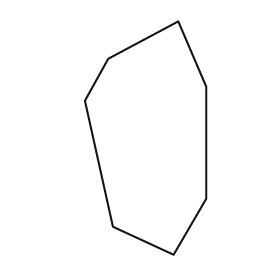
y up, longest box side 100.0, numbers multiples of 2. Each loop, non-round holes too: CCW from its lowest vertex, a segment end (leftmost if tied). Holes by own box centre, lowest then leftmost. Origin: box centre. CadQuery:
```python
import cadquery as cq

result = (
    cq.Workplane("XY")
    .moveTo(12.0, -50.0)
    .lineTo(26.0, -26.0)
    .lineTo(26.0, 22.0)
    .lineTo(14.0, 50.0)
    .lineTo(-16.0, 34.0)
    .lineTo(-26.0, 16.0)
    .lineTo(-14.0, -38.0)
    .close()
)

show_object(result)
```